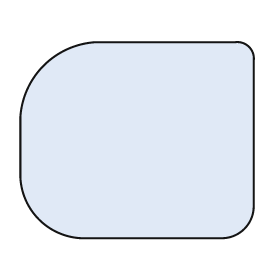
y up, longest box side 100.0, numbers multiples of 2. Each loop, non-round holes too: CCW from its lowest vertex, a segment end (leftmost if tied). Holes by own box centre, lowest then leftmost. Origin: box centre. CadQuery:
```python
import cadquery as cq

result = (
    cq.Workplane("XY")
    .moveTo(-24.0, -42.0)
    .lineTo(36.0, -42.0)
    .threePointArc((46.0, -38.0), (50.0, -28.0))
    .lineTo(50.0, 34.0)
    .threePointArc((48.0, 40.0), (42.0, 42.0))
    .lineTo(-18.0, 42.0)
    .threePointArc((-40.0, 32.0), (-50.0, 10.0))
    .lineTo(-50.0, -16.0)
    .threePointArc((-42.0, -34.0), (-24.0, -42.0))
    .close()
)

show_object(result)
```